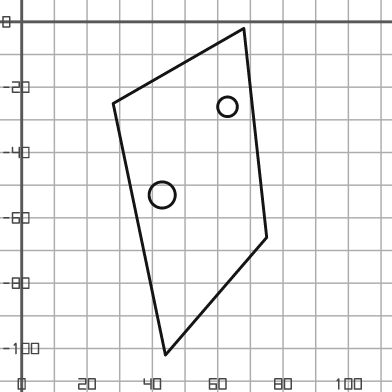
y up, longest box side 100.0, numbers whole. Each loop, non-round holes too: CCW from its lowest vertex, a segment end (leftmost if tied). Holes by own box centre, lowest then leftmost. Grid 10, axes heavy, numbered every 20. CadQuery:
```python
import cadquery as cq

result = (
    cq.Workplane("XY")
    .moveTo(44.0, -102.0)
    .lineTo(75.0, -66.0)
    .lineTo(68.0, -2.0)
    .lineTo(28.0, -25.0)
    .close()
    .moveTo(43.0, -53.0)
    .circle(4.0)
    .moveTo(63.0, -26.0)
    .circle(3.0)
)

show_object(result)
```